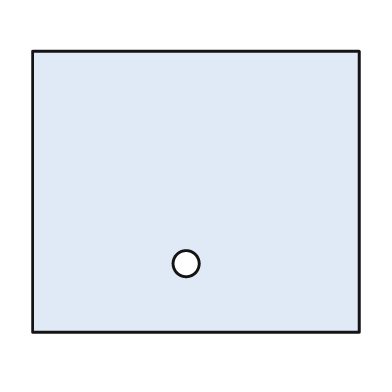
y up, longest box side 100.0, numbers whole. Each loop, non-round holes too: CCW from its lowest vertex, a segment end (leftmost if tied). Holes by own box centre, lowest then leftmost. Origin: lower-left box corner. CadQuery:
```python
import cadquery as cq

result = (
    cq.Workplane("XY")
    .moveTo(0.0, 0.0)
    .lineTo(100.0, 0.0)
    .lineTo(100.0, 86.0)
    .lineTo(0.0, 86.0)
    .close()
    .moveTo(47.0, 21.0)
    .circle(4.0)
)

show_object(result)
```